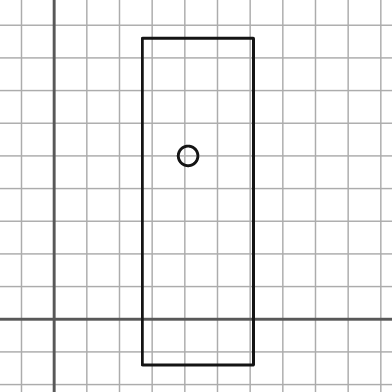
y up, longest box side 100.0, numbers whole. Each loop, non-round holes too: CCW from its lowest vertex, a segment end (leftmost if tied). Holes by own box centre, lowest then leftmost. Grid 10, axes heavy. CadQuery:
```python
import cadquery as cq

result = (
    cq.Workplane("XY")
    .moveTo(27.0, -14.0)
    .lineTo(61.0, -14.0)
    .lineTo(61.0, 86.0)
    .lineTo(27.0, 86.0)
    .close()
    .moveTo(41.0, 50.0)
    .circle(3.0)
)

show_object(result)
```